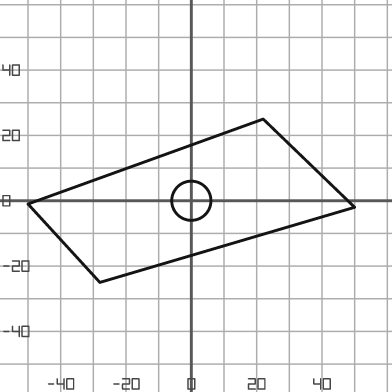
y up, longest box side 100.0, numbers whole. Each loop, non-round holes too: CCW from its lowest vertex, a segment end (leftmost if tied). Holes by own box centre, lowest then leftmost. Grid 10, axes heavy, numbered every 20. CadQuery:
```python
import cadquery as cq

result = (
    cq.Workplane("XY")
    .moveTo(-28.0, -25.0)
    .lineTo(50.0, -2.0)
    .lineTo(22.0, 25.0)
    .lineTo(-50.0, -1.0)
    .close()
    .moveTo(0.0, 0.0)
    .circle(6.0)
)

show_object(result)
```